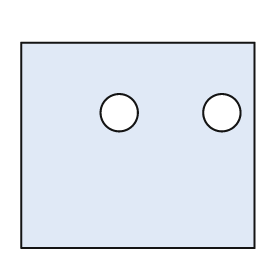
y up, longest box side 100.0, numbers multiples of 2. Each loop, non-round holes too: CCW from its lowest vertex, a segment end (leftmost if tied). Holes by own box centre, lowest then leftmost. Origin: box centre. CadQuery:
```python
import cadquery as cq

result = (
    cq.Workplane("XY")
    .moveTo(-50.0, -44.0)
    .lineTo(50.0, -44.0)
    .lineTo(50.0, 44.0)
    .lineTo(-50.0, 44.0)
    .close()
    .moveTo(-8.0, 14.0)
    .circle(8.0)
    .moveTo(36.0, 14.0)
    .circle(8.0)
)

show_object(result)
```